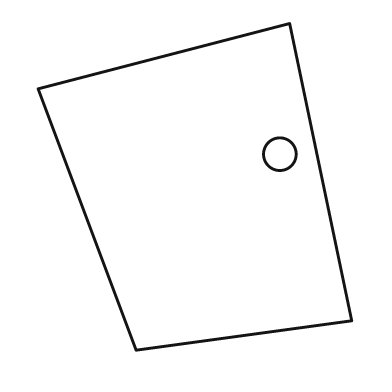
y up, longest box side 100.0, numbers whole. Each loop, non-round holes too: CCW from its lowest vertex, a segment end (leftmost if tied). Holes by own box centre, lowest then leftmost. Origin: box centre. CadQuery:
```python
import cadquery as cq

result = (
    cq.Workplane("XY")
    .moveTo(-18.0, -50.0)
    .lineTo(48.0, -41.0)
    .lineTo(29.0, 50.0)
    .lineTo(-48.0, 30.0)
    .close()
    .moveTo(26.0, 10.0)
    .circle(5.0)
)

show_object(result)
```